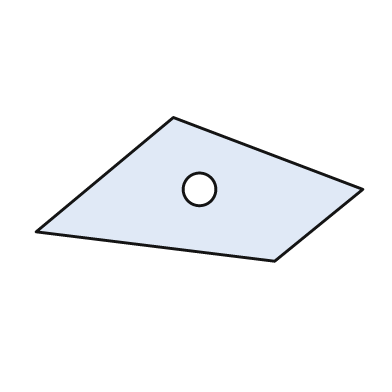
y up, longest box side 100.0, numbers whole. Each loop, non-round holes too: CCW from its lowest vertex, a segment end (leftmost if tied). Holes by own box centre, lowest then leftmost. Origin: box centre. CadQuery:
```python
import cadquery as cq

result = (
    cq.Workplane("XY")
    .moveTo(23.0, -22.0)
    .lineTo(50.0, 0.0)
    .lineTo(-8.0, 22.0)
    .lineTo(-50.0, -13.0)
    .close()
    .moveTo(0.0, 0.0)
    .circle(5.0)
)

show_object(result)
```